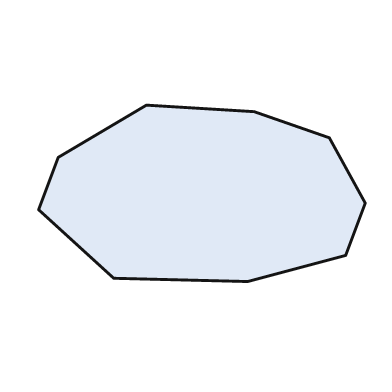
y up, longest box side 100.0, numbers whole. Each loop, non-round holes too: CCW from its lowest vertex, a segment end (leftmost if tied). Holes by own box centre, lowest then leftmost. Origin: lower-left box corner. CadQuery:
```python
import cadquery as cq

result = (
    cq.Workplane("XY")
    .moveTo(64.0, 0.0)
    .lineTo(94.0, 8.0)
    .lineTo(100.0, 24.0)
    .lineTo(89.0, 44.0)
    .lineTo(66.0, 52.0)
    .lineTo(33.0, 54.0)
    .lineTo(6.0, 38.0)
    .lineTo(0.0, 22.0)
    .lineTo(23.0, 1.0)
    .close()
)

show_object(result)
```